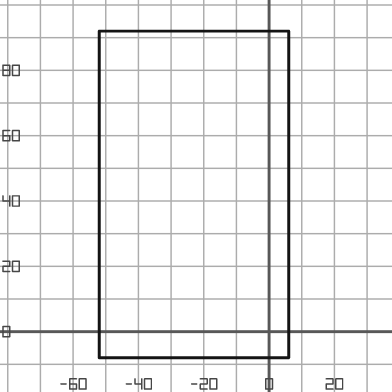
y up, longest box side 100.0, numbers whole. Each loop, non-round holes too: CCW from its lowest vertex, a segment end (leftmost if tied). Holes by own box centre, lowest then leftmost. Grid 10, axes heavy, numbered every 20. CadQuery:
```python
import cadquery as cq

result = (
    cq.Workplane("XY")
    .moveTo(-52.0, -8.0)
    .lineTo(6.0, -8.0)
    .lineTo(6.0, 92.0)
    .lineTo(-52.0, 92.0)
    .close()
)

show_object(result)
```